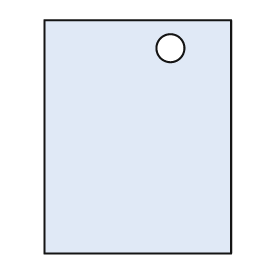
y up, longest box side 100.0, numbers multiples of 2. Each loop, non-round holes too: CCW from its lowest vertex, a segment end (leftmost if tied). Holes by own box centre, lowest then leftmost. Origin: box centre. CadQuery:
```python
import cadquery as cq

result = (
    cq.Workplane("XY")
    .moveTo(-40.0, -50.0)
    .lineTo(40.0, -50.0)
    .lineTo(40.0, 50.0)
    .lineTo(-40.0, 50.0)
    .close()
    .moveTo(14.0, 38.0)
    .circle(6.0)
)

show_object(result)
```